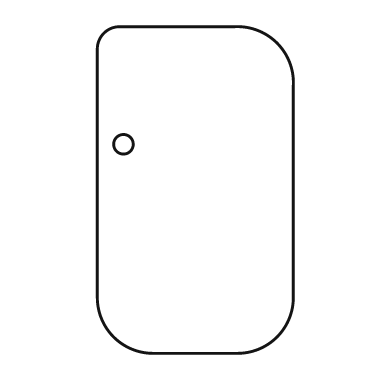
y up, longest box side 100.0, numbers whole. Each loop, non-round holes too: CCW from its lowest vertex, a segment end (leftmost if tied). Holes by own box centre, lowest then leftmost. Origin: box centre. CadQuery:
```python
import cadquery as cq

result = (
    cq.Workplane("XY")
    .moveTo(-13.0, -50.0)
    .lineTo(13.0, -50.0)
    .threePointArc((25.0, -45.0), (30.0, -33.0))
    .lineTo(30.0, 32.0)
    .threePointArc((25.0, 45.0), (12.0, 50.0))
    .lineTo(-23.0, 50.0)
    .threePointArc((-28.0, 48.0), (-30.0, 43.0))
    .lineTo(-30.0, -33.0)
    .threePointArc((-25.0, -45.0), (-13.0, -50.0))
    .close()
    .moveTo(-22.0, 14.0)
    .circle(3.0)
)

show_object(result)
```